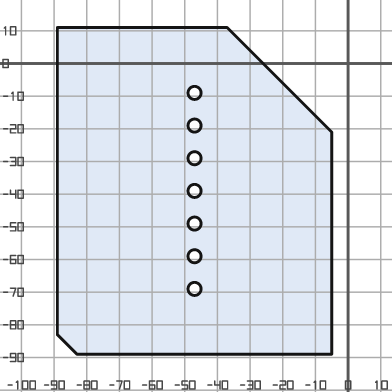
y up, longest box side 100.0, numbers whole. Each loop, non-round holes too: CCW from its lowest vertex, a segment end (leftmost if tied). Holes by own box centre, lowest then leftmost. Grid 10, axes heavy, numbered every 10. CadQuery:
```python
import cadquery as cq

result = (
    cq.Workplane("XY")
    .moveTo(-83.0, -89.0)
    .lineTo(-5.0, -89.0)
    .lineTo(-5.0, -21.0)
    .lineTo(-37.0, 11.0)
    .lineTo(-89.0, 11.0)
    .lineTo(-89.0, -83.0)
    .close()
    .moveTo(-47.0, -69.0)
    .circle(2.0)
    .moveTo(-47.0, -59.0)
    .circle(2.0)
    .moveTo(-47.0, -49.0)
    .circle(2.0)
    .moveTo(-47.0, -39.0)
    .circle(2.0)
    .moveTo(-47.0, -29.0)
    .circle(2.0)
    .moveTo(-47.0, -19.0)
    .circle(2.0)
    .moveTo(-47.0, -9.0)
    .circle(2.0)
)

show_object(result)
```